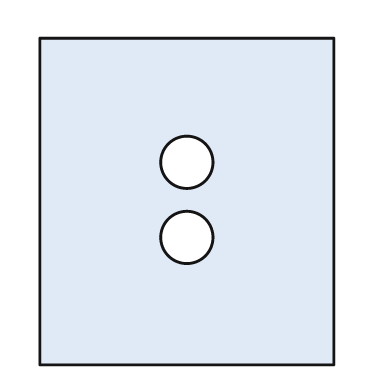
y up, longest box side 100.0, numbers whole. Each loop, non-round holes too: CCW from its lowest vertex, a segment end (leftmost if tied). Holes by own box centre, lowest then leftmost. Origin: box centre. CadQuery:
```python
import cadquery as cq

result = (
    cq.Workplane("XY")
    .moveTo(-45.0, -50.0)
    .lineTo(45.0, -50.0)
    .lineTo(45.0, 50.0)
    .lineTo(-45.0, 50.0)
    .close()
    .moveTo(0.0, -11.0)
    .circle(8.0)
    .moveTo(0.0, 12.0)
    .circle(8.0)
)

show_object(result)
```